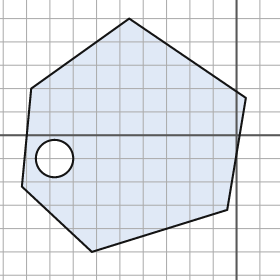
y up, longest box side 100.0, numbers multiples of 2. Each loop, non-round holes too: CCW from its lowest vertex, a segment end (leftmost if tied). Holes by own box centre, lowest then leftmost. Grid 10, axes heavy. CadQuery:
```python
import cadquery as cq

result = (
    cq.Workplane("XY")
    .moveTo(-62.0, -50.0)
    .lineTo(-4.0, -32.0)
    .lineTo(4.0, 16.0)
    .lineTo(-46.0, 50.0)
    .lineTo(-88.0, 20.0)
    .lineTo(-92.0, -22.0)
    .close()
    .moveTo(-78.0, -10.0)
    .circle(8.0)
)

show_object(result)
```